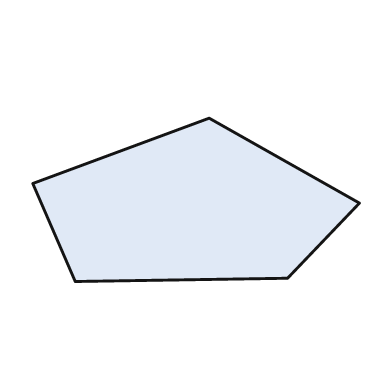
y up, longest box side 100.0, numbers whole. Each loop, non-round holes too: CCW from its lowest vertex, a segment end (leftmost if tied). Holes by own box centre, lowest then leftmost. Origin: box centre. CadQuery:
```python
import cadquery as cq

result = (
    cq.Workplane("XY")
    .moveTo(-37.0, -25.0)
    .lineTo(28.0, -24.0)
    .lineTo(50.0, -1.0)
    .lineTo(4.0, 25.0)
    .lineTo(-50.0, 5.0)
    .close()
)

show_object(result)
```